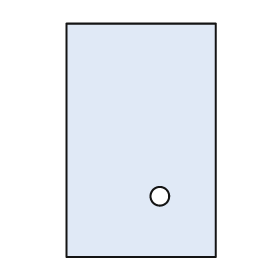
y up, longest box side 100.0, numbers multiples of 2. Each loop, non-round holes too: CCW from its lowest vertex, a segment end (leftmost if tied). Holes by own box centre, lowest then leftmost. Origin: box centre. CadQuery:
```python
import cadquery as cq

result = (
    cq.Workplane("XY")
    .moveTo(-32.0, -50.0)
    .lineTo(32.0, -50.0)
    .lineTo(32.0, 50.0)
    .lineTo(-32.0, 50.0)
    .close()
    .moveTo(8.0, -24.0)
    .circle(4.0)
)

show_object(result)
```